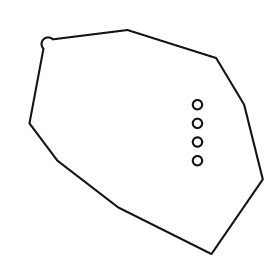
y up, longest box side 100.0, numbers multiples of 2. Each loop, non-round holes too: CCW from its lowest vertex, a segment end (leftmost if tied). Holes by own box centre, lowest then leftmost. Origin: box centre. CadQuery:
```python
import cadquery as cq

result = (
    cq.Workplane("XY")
    .moveTo(28.0, -48.0)
    .lineTo(50.0, -16.0)
    .lineTo(42.0, 16.0)
    .lineTo(30.0, 36.0)
    .lineTo(-8.0, 48.0)
    .lineTo(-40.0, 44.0)
    .threePointArc((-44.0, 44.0), (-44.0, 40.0))
    .lineTo(-50.0, 8.0)
    .lineTo(-38.0, -8.0)
    .lineTo(-12.0, -28.0)
    .close()
    .moveTo(22.0, -8.0)
    .circle(2.0)
    .moveTo(22.0, 0.0)
    .circle(2.0)
    .moveTo(22.0, 8.0)
    .circle(2.0)
    .moveTo(22.0, 16.0)
    .circle(2.0)
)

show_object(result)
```